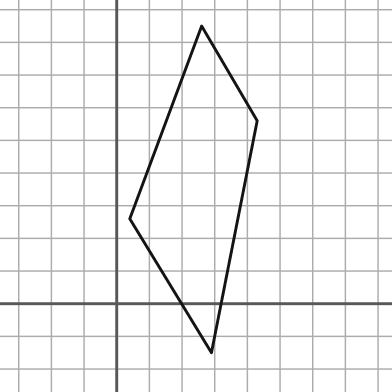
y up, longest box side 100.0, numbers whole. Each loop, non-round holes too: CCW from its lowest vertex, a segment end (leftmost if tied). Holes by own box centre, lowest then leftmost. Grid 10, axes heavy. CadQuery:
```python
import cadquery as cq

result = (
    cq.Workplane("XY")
    .moveTo(29.0, -15.0)
    .lineTo(43.0, 56.0)
    .lineTo(26.0, 85.0)
    .lineTo(4.0, 26.0)
    .close()
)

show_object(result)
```